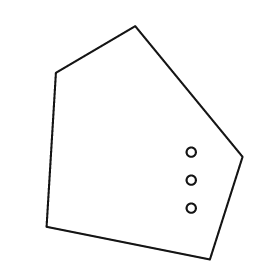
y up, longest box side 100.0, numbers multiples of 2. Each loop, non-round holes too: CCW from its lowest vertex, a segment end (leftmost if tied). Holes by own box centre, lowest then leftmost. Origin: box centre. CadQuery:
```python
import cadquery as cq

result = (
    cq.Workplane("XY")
    .moveTo(28.0, -50.0)
    .lineTo(42.0, -6.0)
    .lineTo(-4.0, 50.0)
    .lineTo(-38.0, 30.0)
    .lineTo(-42.0, -36.0)
    .close()
    .moveTo(20.0, -28.0)
    .circle(2.0)
    .moveTo(20.0, -16.0)
    .circle(2.0)
    .moveTo(20.0, -4.0)
    .circle(2.0)
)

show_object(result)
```